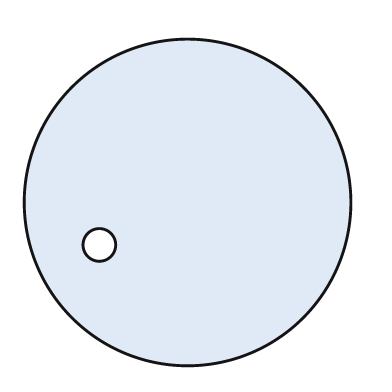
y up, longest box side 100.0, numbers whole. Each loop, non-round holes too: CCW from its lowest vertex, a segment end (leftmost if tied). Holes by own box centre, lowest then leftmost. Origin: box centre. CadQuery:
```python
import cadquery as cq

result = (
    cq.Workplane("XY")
    .moveTo(0.0, 0.0)
    .circle(50.0)
    .moveTo(-27.0, -13.0)
    .circle(5.0)
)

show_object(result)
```